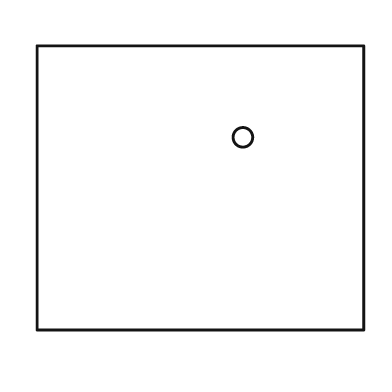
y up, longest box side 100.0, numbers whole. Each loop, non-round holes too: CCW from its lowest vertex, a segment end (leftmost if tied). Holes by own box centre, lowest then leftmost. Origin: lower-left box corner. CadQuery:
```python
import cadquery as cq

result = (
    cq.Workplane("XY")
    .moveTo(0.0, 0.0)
    .lineTo(100.0, 0.0)
    .lineTo(100.0, 87.0)
    .lineTo(0.0, 87.0)
    .close()
    .moveTo(63.0, 59.0)
    .circle(3.0)
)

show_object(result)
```